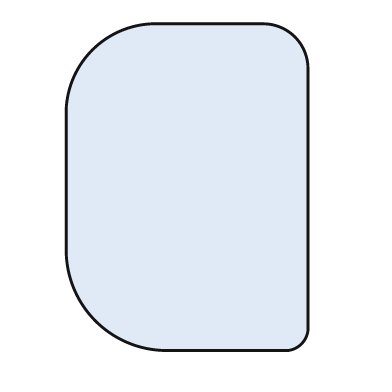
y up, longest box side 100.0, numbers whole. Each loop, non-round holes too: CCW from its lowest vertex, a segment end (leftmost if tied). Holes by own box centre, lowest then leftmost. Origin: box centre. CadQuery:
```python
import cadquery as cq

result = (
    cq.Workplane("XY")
    .moveTo(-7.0, -50.0)
    .lineTo(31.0, -50.0)
    .threePointArc((35.0, -48.0), (37.0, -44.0))
    .lineTo(37.0, 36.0)
    .threePointArc((33.0, 46.0), (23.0, 50.0))
    .lineTo(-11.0, 50.0)
    .threePointArc((-29.0, 42.0), (-37.0, 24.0))
    .lineTo(-37.0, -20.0)
    .threePointArc((-28.0, -41.0), (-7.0, -50.0))
    .close()
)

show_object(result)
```